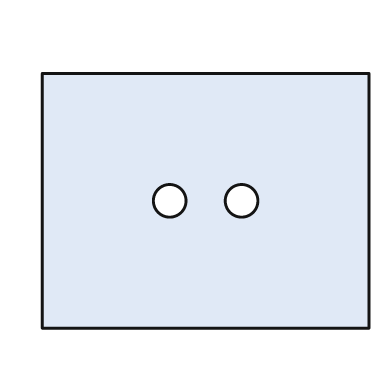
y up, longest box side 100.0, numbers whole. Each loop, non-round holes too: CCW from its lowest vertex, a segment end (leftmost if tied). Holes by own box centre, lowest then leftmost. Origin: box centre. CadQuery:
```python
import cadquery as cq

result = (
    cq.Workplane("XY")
    .moveTo(-50.0, -39.0)
    .lineTo(50.0, -39.0)
    .lineTo(50.0, 39.0)
    .lineTo(-50.0, 39.0)
    .close()
    .moveTo(-11.0, 0.0)
    .circle(5.0)
    .moveTo(11.0, 0.0)
    .circle(5.0)
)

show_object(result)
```